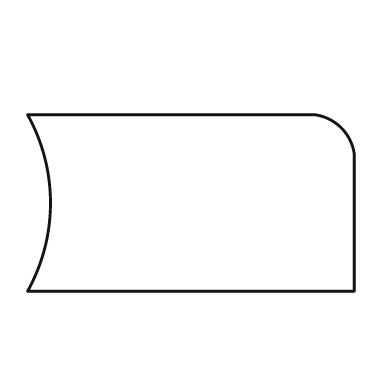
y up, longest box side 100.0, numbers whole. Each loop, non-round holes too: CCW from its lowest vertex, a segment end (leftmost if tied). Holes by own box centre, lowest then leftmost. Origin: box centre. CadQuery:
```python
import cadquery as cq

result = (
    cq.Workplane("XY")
    .moveTo(-50.0, -27.0)
    .lineTo(50.0, -27.0)
    .lineTo(50.0, 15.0)
    .threePointArc((46.0, 23.0), (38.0, 27.0))
    .lineTo(-50.0, 27.0)
    .threePointArc((-43.0, 0.0), (-50.0, -27.0))
    .close()
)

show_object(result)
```